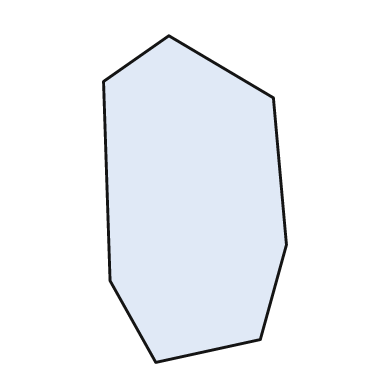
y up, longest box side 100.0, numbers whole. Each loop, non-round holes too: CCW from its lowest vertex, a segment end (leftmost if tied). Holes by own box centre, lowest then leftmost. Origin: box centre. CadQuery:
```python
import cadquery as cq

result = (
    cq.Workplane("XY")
    .moveTo(-12.0, -50.0)
    .lineTo(20.0, -43.0)
    .lineTo(28.0, -14.0)
    .lineTo(24.0, 31.0)
    .lineTo(-8.0, 50.0)
    .lineTo(-28.0, 36.0)
    .lineTo(-26.0, -25.0)
    .close()
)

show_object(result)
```